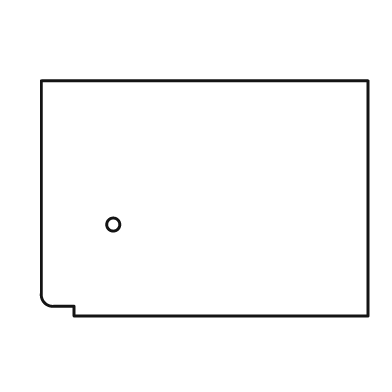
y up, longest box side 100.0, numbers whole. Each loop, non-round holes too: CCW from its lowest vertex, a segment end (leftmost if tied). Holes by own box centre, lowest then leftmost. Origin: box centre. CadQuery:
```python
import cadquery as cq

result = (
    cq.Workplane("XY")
    .moveTo(-40.0, -36.0)
    .lineTo(50.0, -36.0)
    .lineTo(50.0, 36.0)
    .lineTo(-50.0, 36.0)
    .lineTo(-50.0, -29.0)
    .threePointArc((-49.0, -32.0), (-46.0, -33.0))
    .lineTo(-40.0, -33.0)
    .close()
    .moveTo(-28.0, -8.0)
    .circle(2.0)
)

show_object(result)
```